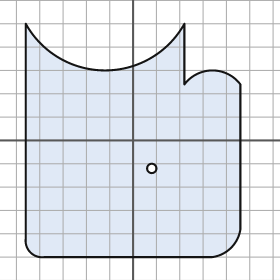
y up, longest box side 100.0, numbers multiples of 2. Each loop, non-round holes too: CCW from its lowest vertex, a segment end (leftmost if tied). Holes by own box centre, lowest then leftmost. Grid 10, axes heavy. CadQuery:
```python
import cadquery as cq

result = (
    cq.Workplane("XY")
    .moveTo(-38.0, -50.0)
    .lineTo(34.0, -50.0)
    .threePointArc((42.0, -46.0), (46.0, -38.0))
    .lineTo(46.0, 24.0)
    .threePointArc((34.0, 30.0), (22.0, 24.0))
    .lineTo(22.0, 50.0)
    .threePointArc((-12.0, 30.0), (-46.0, 50.0))
    .lineTo(-46.0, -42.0)
    .threePointArc((-44.0, -48.0), (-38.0, -50.0))
    .close()
    .moveTo(8.0, -12.0)
    .circle(2.0)
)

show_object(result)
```